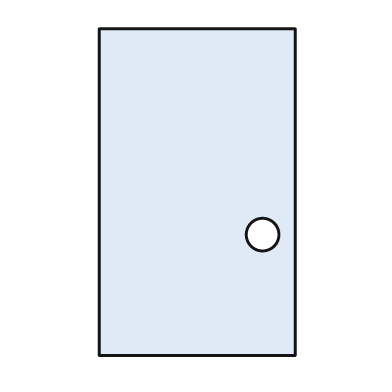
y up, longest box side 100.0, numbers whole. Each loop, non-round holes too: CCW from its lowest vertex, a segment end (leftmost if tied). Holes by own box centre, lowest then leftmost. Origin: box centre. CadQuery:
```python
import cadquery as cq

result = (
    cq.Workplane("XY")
    .moveTo(-30.0, -50.0)
    .lineTo(30.0, -50.0)
    .lineTo(30.0, 50.0)
    .lineTo(-30.0, 50.0)
    .close()
    .moveTo(20.0, -13.0)
    .circle(5.0)
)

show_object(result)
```